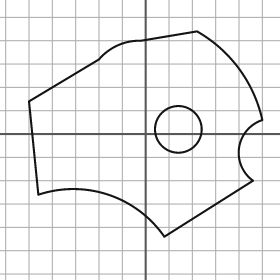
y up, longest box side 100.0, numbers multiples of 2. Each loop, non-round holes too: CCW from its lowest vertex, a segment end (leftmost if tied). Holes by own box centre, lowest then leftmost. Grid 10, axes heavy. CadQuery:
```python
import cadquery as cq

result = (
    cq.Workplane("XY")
    .moveTo(8.0, -44.0)
    .lineTo(46.0, -20.0)
    .threePointArc((40.0, -6.0), (50.0, 6.0))
    .threePointArc((40.0, 28.0), (22.0, 44.0))
    .lineTo(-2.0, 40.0)
    .threePointArc((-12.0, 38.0), (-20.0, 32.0))
    .lineTo(-50.0, 14.0)
    .lineTo(-46.0, -26.0)
    .threePointArc((-16.0, -26.0), (8.0, -44.0))
    .close()
    .moveTo(14.0, 2.0)
    .circle(10.0)
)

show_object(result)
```